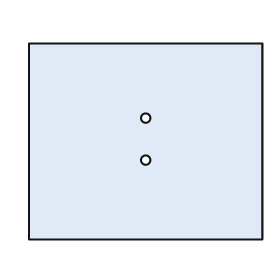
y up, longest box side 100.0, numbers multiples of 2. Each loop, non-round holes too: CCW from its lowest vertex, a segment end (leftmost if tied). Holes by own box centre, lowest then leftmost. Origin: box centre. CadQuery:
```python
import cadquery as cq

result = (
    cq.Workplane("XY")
    .moveTo(-50.0, -42.0)
    .lineTo(50.0, -42.0)
    .lineTo(50.0, 42.0)
    .lineTo(-50.0, 42.0)
    .close()
    .moveTo(0.0, -8.0)
    .circle(2.0)
    .moveTo(0.0, 10.0)
    .circle(2.0)
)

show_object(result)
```